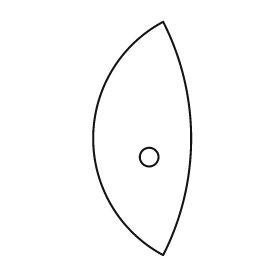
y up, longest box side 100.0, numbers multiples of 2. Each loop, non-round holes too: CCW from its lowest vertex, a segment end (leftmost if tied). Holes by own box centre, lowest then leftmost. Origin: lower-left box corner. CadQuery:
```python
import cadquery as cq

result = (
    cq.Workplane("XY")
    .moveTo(30.0, 0.0)
    .threePointArc((42.0, 50.0), (30.0, 100.0))
    .threePointArc((0.0, 50.0), (30.0, 0.0))
    .close()
    .moveTo(24.0, 42.0)
    .circle(4.0)
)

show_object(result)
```